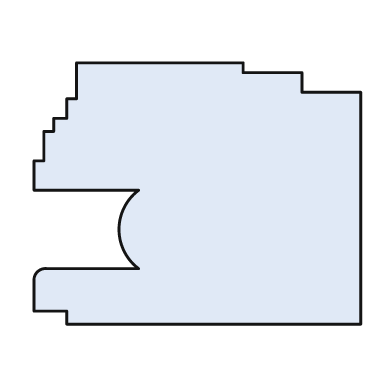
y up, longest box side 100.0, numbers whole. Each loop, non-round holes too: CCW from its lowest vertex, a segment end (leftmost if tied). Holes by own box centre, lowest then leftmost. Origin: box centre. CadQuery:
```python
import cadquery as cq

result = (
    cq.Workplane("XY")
    .moveTo(-40.0, -40.0)
    .lineTo(50.0, -40.0)
    .lineTo(50.0, 31.0)
    .lineTo(32.0, 31.0)
    .lineTo(32.0, 37.0)
    .lineTo(14.0, 37.0)
    .lineTo(14.0, 40.0)
    .lineTo(-37.0, 40.0)
    .lineTo(-37.0, 29.0)
    .lineTo(-40.0, 29.0)
    .lineTo(-40.0, 23.0)
    .lineTo(-44.0, 23.0)
    .lineTo(-44.0, 19.0)
    .lineTo(-47.0, 19.0)
    .lineTo(-47.0, 10.0)
    .lineTo(-50.0, 10.0)
    .lineTo(-50.0, 1.0)
    .lineTo(-18.0, 1.0)
    .threePointArc((-24.0, -11.0), (-18.0, -23.0))
    .lineTo(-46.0, -23.0)
    .threePointArc((-49.0, -24.0), (-50.0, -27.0))
    .lineTo(-50.0, -36.0)
    .lineTo(-40.0, -36.0)
    .close()
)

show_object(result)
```